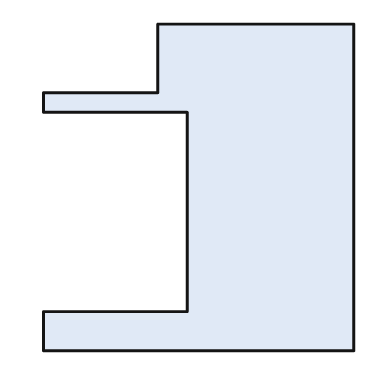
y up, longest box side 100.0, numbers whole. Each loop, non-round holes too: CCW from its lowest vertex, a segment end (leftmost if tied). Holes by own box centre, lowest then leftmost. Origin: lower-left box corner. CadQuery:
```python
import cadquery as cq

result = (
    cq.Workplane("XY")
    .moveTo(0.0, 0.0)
    .lineTo(95.0, 0.0)
    .lineTo(95.0, 100.0)
    .lineTo(35.0, 100.0)
    .lineTo(35.0, 79.0)
    .lineTo(0.0, 79.0)
    .lineTo(0.0, 73.0)
    .lineTo(44.0, 73.0)
    .lineTo(44.0, 12.0)
    .lineTo(0.0, 12.0)
    .close()
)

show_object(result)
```